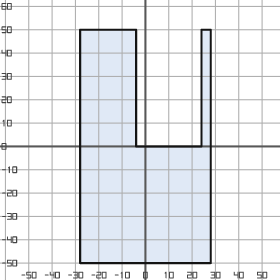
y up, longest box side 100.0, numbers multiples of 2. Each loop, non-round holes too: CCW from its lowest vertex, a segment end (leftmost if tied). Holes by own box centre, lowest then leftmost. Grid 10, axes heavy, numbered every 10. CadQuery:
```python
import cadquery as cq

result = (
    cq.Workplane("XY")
    .moveTo(-28.0, -50.0)
    .lineTo(28.0, -50.0)
    .lineTo(28.0, 50.0)
    .lineTo(24.0, 50.0)
    .lineTo(24.0, 0.0)
    .lineTo(-4.0, 0.0)
    .lineTo(-4.0, 50.0)
    .lineTo(-28.0, 50.0)
    .close()
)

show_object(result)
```